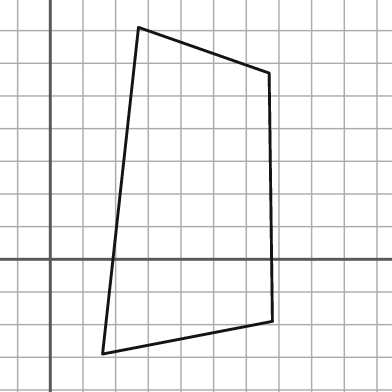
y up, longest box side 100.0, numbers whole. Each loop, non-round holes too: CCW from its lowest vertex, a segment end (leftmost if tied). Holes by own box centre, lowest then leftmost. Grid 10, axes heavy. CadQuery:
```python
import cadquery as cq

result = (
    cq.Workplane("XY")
    .moveTo(16.0, -29.0)
    .lineTo(68.0, -19.0)
    .lineTo(67.0, 57.0)
    .lineTo(27.0, 71.0)
    .close()
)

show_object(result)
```